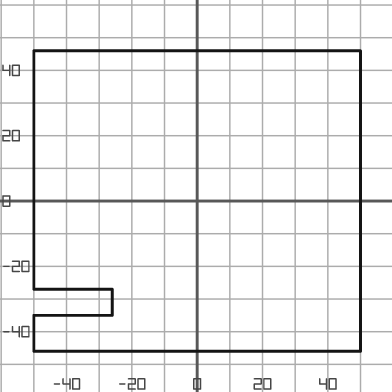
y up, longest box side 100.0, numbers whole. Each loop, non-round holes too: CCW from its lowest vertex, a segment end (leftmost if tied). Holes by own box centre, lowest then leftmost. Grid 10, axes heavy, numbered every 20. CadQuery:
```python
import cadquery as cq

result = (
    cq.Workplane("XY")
    .moveTo(-50.0, -46.0)
    .lineTo(50.0, -46.0)
    .lineTo(50.0, 46.0)
    .lineTo(-50.0, 46.0)
    .lineTo(-50.0, -27.0)
    .lineTo(-26.0, -27.0)
    .lineTo(-26.0, -35.0)
    .lineTo(-50.0, -35.0)
    .close()
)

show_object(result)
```